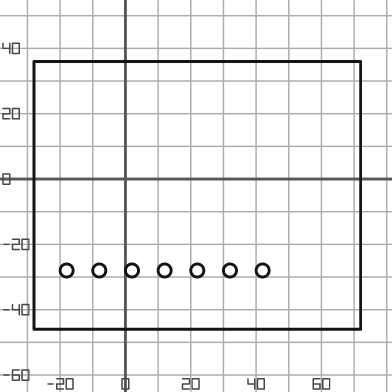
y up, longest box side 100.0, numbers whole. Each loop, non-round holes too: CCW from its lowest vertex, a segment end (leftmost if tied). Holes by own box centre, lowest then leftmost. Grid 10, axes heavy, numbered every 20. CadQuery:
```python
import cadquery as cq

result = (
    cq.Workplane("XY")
    .moveTo(-28.0, -46.0)
    .lineTo(72.0, -46.0)
    .lineTo(72.0, 36.0)
    .lineTo(-28.0, 36.0)
    .close()
    .moveTo(-18.0, -28.0)
    .circle(2.0)
    .moveTo(-8.0, -28.0)
    .circle(2.0)
    .moveTo(2.0, -28.0)
    .circle(2.0)
    .moveTo(12.0, -28.0)
    .circle(2.0)
    .moveTo(22.0, -28.0)
    .circle(2.0)
    .moveTo(32.0, -28.0)
    .circle(2.0)
    .moveTo(42.0, -28.0)
    .circle(2.0)
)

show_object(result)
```